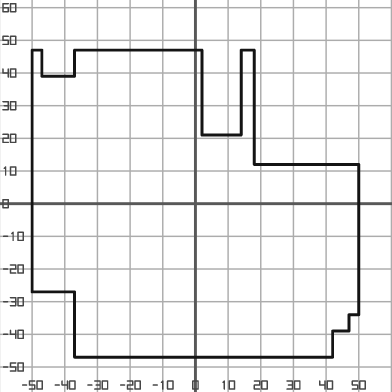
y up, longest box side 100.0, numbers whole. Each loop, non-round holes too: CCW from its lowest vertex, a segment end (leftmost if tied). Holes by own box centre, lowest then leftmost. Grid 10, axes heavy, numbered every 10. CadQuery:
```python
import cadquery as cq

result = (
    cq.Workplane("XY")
    .moveTo(-37.0, -47.0)
    .lineTo(42.0, -47.0)
    .lineTo(42.0, -39.0)
    .lineTo(47.0, -39.0)
    .lineTo(47.0, -34.0)
    .lineTo(50.0, -34.0)
    .lineTo(50.0, 12.0)
    .lineTo(18.0, 12.0)
    .lineTo(18.0, 47.0)
    .lineTo(14.0, 47.0)
    .lineTo(14.0, 21.0)
    .lineTo(2.0, 21.0)
    .lineTo(2.0, 47.0)
    .lineTo(-37.0, 47.0)
    .lineTo(-37.0, 39.0)
    .lineTo(-47.0, 39.0)
    .lineTo(-47.0, 47.0)
    .lineTo(-50.0, 47.0)
    .lineTo(-50.0, -27.0)
    .lineTo(-37.0, -27.0)
    .close()
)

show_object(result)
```